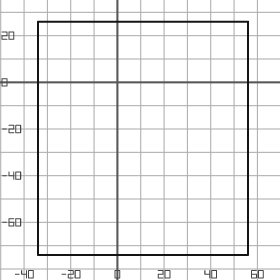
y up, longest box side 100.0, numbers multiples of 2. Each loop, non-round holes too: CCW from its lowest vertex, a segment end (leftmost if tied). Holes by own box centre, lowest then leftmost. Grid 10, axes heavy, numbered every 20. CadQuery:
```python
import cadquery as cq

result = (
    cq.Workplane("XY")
    .moveTo(-34.0, -74.0)
    .lineTo(56.0, -74.0)
    .lineTo(56.0, 26.0)
    .lineTo(-34.0, 26.0)
    .close()
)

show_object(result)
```